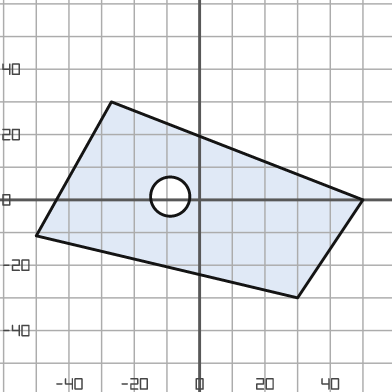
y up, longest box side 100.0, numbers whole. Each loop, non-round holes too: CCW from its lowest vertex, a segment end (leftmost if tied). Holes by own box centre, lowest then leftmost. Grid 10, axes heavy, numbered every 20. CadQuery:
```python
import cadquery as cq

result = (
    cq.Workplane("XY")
    .moveTo(30.0, -30.0)
    .lineTo(50.0, 0.0)
    .lineTo(-27.0, 30.0)
    .lineTo(-50.0, -11.0)
    .close()
    .moveTo(-9.0, 1.0)
    .circle(6.0)
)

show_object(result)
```